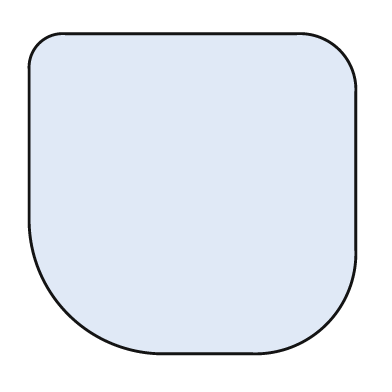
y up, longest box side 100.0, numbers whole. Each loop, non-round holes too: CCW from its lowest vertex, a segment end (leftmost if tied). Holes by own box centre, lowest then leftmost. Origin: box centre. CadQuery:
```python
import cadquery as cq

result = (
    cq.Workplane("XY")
    .moveTo(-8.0, -49.0)
    .lineTo(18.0, -49.0)
    .threePointArc((41.0, -40.0), (50.0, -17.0))
    .lineTo(50.0, 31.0)
    .threePointArc((45.0, 44.0), (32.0, 49.0))
    .lineTo(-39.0, 49.0)
    .threePointArc((-47.0, 46.0), (-50.0, 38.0))
    .lineTo(-50.0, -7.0)
    .threePointArc((-38.0, -37.0), (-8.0, -49.0))
    .close()
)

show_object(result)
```